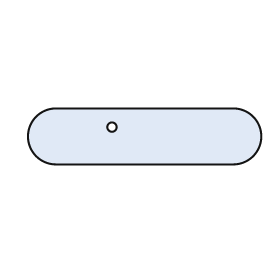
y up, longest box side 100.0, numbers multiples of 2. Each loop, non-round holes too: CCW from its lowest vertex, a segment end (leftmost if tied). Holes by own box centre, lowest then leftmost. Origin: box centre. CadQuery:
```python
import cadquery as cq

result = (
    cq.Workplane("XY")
    .moveTo(-38.0, -12.0)
    .lineTo(38.0, -12.0)
    .threePointArc((50.0, 0.0), (38.0, 12.0))
    .lineTo(-38.0, 12.0)
    .threePointArc((-50.0, 0.0), (-38.0, -12.0))
    .close()
    .moveTo(-14.0, 4.0)
    .circle(2.0)
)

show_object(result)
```